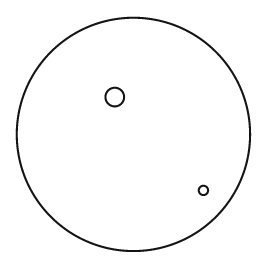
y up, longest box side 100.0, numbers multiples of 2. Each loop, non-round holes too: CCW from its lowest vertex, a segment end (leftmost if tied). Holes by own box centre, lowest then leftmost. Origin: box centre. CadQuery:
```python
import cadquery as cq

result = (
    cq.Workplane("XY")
    .moveTo(0.0, 0.0)
    .circle(50.0)
    .moveTo(30.0, -24.0)
    .circle(2.0)
    .moveTo(-8.0, 16.0)
    .circle(4.0)
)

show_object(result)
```